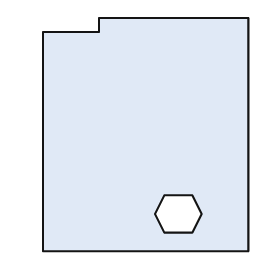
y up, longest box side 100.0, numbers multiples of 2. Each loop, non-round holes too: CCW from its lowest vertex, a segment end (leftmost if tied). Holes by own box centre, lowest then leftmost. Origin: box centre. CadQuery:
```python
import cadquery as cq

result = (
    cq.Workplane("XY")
    .moveTo(-44.0, -50.0)
    .lineTo(44.0, -50.0)
    .lineTo(44.0, 50.0)
    .lineTo(-20.0, 50.0)
    .lineTo(-20.0, 44.0)
    .lineTo(-44.0, 44.0)
    .close()
    .moveTo(8.0, -42.0)
    .lineTo(20.0, -42.0)
    .lineTo(24.0, -34.0)
    .lineTo(20.0, -26.0)
    .lineTo(8.0, -26.0)
    .lineTo(4.0, -34.0)
    .close()
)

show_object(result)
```